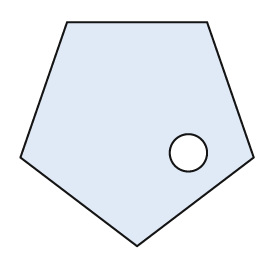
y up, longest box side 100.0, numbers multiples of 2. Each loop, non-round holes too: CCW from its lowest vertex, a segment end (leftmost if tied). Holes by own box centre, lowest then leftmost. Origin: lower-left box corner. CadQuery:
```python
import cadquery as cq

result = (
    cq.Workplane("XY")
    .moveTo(50.0, 0.0)
    .lineTo(100.0, 38.0)
    .lineTo(80.0, 96.0)
    .lineTo(20.0, 96.0)
    .lineTo(0.0, 38.0)
    .close()
    .moveTo(72.0, 40.0)
    .circle(8.0)
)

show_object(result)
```